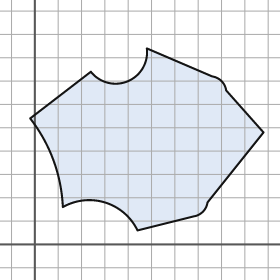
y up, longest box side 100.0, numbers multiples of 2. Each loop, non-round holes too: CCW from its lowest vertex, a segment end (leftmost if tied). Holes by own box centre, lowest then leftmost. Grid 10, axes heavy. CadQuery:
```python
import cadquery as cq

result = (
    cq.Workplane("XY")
    .moveTo(44.0, 6.0)
    .lineTo(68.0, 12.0)
    .threePointArc((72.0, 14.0), (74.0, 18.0))
    .lineTo(98.0, 48.0)
    .lineTo(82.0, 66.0)
    .threePointArc((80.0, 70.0), (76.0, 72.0))
    .lineTo(48.0, 84.0)
    .threePointArc((40.0, 70.0), (24.0, 74.0))
    .lineTo(-2.0, 54.0)
    .threePointArc((8.0, 36.0), (12.0, 16.0))
    .threePointArc((30.0, 18.0), (44.0, 6.0))
    .close()
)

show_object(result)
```